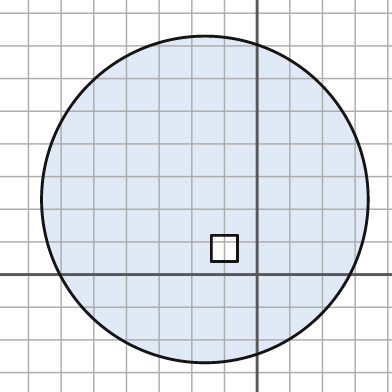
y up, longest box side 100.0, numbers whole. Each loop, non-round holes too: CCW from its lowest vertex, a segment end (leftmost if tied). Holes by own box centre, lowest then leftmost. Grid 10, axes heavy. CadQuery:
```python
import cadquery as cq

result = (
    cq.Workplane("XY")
    .moveTo(-16.0, 23.0)
    .circle(50.0)
    .moveTo(-14.0, 4.0)
    .lineTo(-6.0, 4.0)
    .lineTo(-6.0, 12.0)
    .lineTo(-14.0, 12.0)
    .close()
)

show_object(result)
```